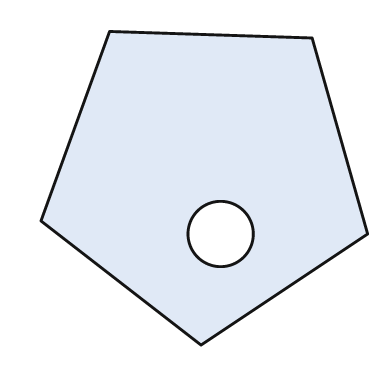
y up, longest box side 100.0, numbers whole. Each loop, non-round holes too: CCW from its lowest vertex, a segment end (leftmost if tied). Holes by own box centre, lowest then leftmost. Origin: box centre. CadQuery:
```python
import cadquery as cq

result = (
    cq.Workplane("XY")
    .moveTo(-1.0, -48.0)
    .lineTo(50.0, -14.0)
    .lineTo(33.0, 46.0)
    .lineTo(-29.0, 48.0)
    .lineTo(-50.0, -10.0)
    .close()
    .moveTo(5.0, -14.0)
    .circle(10.0)
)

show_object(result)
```